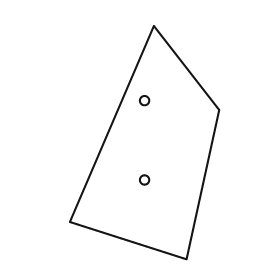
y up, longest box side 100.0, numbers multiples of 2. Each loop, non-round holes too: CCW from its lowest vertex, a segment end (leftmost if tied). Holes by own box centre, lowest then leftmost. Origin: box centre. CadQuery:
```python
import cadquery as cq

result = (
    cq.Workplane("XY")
    .moveTo(18.0, -50.0)
    .lineTo(32.0, 14.0)
    .lineTo(4.0, 50.0)
    .lineTo(-32.0, -34.0)
    .close()
    .moveTo(0.0, -16.0)
    .circle(2.0)
    .moveTo(0.0, 18.0)
    .circle(2.0)
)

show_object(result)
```